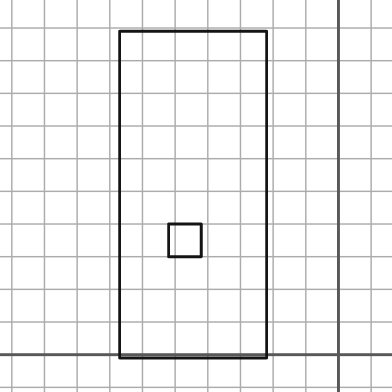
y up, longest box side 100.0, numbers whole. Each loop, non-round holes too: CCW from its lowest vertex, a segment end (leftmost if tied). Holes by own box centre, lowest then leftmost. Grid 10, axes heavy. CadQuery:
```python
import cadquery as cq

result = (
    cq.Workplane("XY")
    .moveTo(-67.0, -1.0)
    .lineTo(-22.0, -1.0)
    .lineTo(-22.0, 99.0)
    .lineTo(-67.0, 99.0)
    .close()
    .moveTo(-52.0, 30.0)
    .lineTo(-42.0, 30.0)
    .lineTo(-42.0, 40.0)
    .lineTo(-52.0, 40.0)
    .close()
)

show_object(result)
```